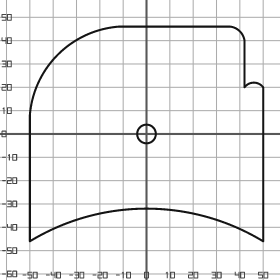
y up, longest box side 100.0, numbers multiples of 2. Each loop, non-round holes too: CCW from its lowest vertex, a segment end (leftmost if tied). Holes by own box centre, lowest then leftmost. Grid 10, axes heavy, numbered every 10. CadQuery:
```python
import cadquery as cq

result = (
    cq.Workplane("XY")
    .moveTo(-50.0, -46.0)
    .threePointArc((0.0, -32.0), (50.0, -46.0))
    .lineTo(50.0, 20.0)
    .threePointArc((46.0, 22.0), (42.0, 20.0))
    .lineTo(42.0, 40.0)
    .threePointArc((40.0, 44.0), (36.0, 46.0))
    .lineTo(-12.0, 46.0)
    .threePointArc((-38.0, 34.0), (-50.0, 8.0))
    .close()
    .moveTo(0.0, 0.0)
    .circle(4.0)
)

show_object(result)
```